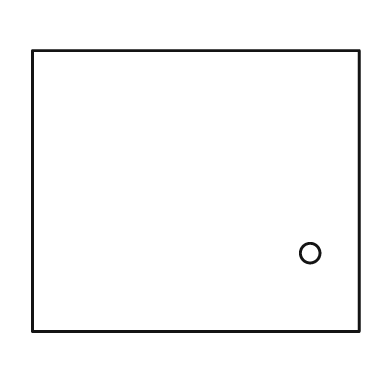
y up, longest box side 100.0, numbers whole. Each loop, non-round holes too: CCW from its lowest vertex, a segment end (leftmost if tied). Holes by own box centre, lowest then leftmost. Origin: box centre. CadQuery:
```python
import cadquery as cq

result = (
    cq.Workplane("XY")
    .moveTo(-50.0, -43.0)
    .lineTo(50.0, -43.0)
    .lineTo(50.0, 43.0)
    .lineTo(-50.0, 43.0)
    .close()
    .moveTo(35.0, -19.0)
    .circle(3.0)
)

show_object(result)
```